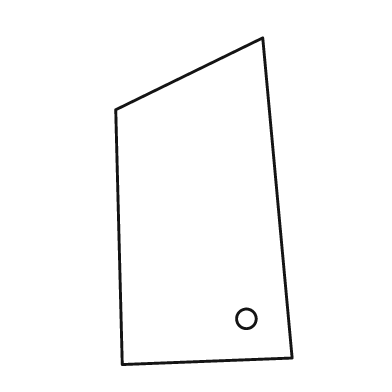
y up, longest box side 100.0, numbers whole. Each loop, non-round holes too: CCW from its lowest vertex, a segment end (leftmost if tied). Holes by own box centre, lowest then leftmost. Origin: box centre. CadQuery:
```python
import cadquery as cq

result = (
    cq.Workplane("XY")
    .moveTo(-25.0, -50.0)
    .lineTo(27.0, -48.0)
    .lineTo(18.0, 50.0)
    .lineTo(-27.0, 28.0)
    .close()
    .moveTo(13.0, -36.0)
    .circle(3.0)
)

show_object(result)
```